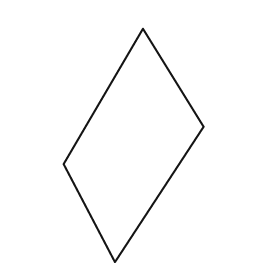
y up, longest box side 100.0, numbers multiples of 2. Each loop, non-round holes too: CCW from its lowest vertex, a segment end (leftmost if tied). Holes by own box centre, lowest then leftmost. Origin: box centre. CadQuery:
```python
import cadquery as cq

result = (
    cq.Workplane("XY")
    .moveTo(-8.0, -50.0)
    .lineTo(30.0, 8.0)
    .lineTo(4.0, 50.0)
    .lineTo(-30.0, -8.0)
    .close()
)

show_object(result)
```